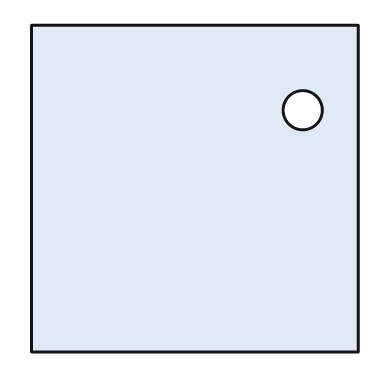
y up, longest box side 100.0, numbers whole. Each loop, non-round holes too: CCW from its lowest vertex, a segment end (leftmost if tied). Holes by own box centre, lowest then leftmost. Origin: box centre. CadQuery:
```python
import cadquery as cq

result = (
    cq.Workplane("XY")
    .moveTo(-50.0, -50.0)
    .lineTo(50.0, -50.0)
    .lineTo(50.0, 50.0)
    .lineTo(-50.0, 50.0)
    .close()
    .moveTo(33.0, 24.0)
    .circle(6.0)
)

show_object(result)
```